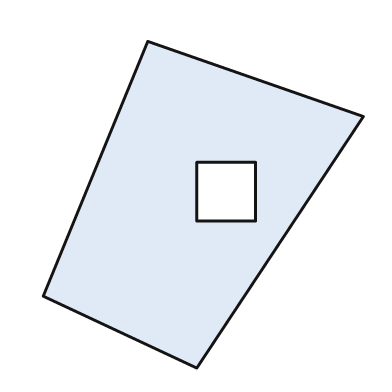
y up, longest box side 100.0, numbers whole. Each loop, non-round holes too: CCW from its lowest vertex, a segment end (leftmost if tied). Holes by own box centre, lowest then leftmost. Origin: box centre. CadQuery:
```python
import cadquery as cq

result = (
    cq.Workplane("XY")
    .moveTo(-2.0, -50.0)
    .lineTo(49.0, 27.0)
    .lineTo(-17.0, 50.0)
    .lineTo(-49.0, -28.0)
    .close()
    .moveTo(-2.0, -5.0)
    .lineTo(16.0, -5.0)
    .lineTo(16.0, 13.0)
    .lineTo(-2.0, 13.0)
    .close()
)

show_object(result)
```